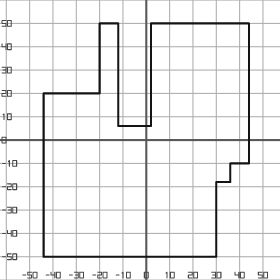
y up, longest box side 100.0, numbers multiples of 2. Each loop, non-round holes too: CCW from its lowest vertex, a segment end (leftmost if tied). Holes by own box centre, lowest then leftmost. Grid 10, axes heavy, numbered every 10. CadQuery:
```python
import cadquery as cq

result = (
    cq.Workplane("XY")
    .moveTo(-44.0, -50.0)
    .lineTo(30.0, -50.0)
    .lineTo(30.0, -18.0)
    .lineTo(36.0, -18.0)
    .lineTo(36.0, -10.0)
    .lineTo(44.0, -10.0)
    .lineTo(44.0, 50.0)
    .lineTo(2.0, 50.0)
    .lineTo(2.0, 6.0)
    .lineTo(-12.0, 6.0)
    .lineTo(-12.0, 50.0)
    .lineTo(-20.0, 50.0)
    .lineTo(-20.0, 20.0)
    .lineTo(-44.0, 20.0)
    .close()
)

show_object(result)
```